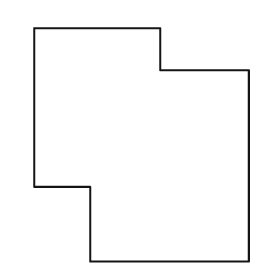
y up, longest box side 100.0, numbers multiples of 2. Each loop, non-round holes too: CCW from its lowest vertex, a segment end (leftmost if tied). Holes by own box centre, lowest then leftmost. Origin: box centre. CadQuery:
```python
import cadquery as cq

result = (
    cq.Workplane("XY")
    .moveTo(-22.0, -50.0)
    .lineTo(46.0, -50.0)
    .lineTo(46.0, 32.0)
    .lineTo(8.0, 32.0)
    .lineTo(8.0, 50.0)
    .lineTo(-46.0, 50.0)
    .lineTo(-46.0, -18.0)
    .lineTo(-22.0, -18.0)
    .close()
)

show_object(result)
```